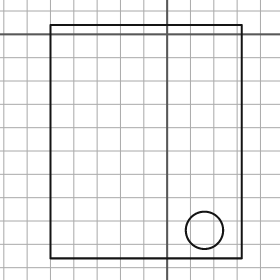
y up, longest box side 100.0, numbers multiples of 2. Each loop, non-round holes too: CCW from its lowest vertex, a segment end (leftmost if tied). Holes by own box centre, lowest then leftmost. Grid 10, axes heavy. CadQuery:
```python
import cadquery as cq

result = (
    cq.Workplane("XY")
    .moveTo(-50.0, -96.0)
    .lineTo(32.0, -96.0)
    .lineTo(32.0, 4.0)
    .lineTo(-50.0, 4.0)
    .close()
    .moveTo(16.0, -84.0)
    .circle(8.0)
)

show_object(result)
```